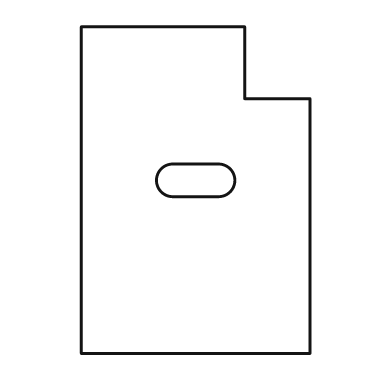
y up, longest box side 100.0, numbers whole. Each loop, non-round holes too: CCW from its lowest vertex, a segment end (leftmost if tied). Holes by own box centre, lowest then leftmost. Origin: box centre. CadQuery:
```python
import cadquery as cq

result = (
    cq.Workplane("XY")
    .moveTo(-35.0, -50.0)
    .lineTo(35.0, -50.0)
    .lineTo(35.0, 28.0)
    .lineTo(15.0, 28.0)
    .lineTo(15.0, 50.0)
    .lineTo(-35.0, 50.0)
    .close()
    .moveTo(-7.0, -2.0)
    .lineTo(7.0, -2.0)
    .threePointArc((12.0, 3.0), (7.0, 8.0))
    .lineTo(-7.0, 8.0)
    .threePointArc((-12.0, 3.0), (-7.0, -2.0))
    .close()
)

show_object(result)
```